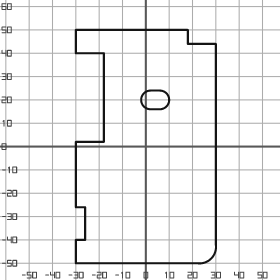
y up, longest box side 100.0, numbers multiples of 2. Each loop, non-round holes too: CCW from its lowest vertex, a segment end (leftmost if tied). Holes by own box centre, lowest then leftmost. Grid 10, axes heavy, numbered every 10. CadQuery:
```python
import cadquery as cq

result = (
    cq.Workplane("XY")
    .moveTo(-30.0, -50.0)
    .lineTo(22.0, -50.0)
    .threePointArc((28.0, -48.0), (30.0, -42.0))
    .lineTo(30.0, 44.0)
    .lineTo(18.0, 44.0)
    .lineTo(18.0, 50.0)
    .lineTo(-30.0, 50.0)
    .lineTo(-30.0, 40.0)
    .lineTo(-18.0, 40.0)
    .lineTo(-18.0, 2.0)
    .lineTo(-30.0, 2.0)
    .lineTo(-30.0, -26.0)
    .lineTo(-26.0, -26.0)
    .lineTo(-26.0, -40.0)
    .lineTo(-30.0, -40.0)
    .close()
    .moveTo(2.0, 16.0)
    .lineTo(6.0, 16.0)
    .threePointArc((10.0, 20.0), (6.0, 24.0))
    .lineTo(2.0, 24.0)
    .threePointArc((-2.0, 20.0), (2.0, 16.0))
    .close()
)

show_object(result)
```